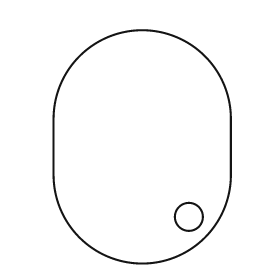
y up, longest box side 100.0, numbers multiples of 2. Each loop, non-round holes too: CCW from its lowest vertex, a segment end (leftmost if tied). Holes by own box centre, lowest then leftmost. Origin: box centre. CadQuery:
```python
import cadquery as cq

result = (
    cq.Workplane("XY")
    .moveTo(-38.0, -12.0)
    .threePointArc((0.0, -50.0), (38.0, -12.0))
    .lineTo(38.0, 12.0)
    .threePointArc((0.0, 50.0), (-38.0, 12.0))
    .close()
    .moveTo(20.0, -30.0)
    .circle(6.0)
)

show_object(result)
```